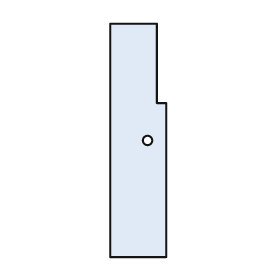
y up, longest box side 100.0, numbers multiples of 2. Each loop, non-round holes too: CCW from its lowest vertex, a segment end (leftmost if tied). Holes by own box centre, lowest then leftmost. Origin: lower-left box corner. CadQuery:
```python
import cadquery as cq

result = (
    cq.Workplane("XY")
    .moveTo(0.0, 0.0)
    .lineTo(24.0, 0.0)
    .lineTo(24.0, 66.0)
    .lineTo(20.0, 66.0)
    .lineTo(20.0, 100.0)
    .lineTo(0.0, 100.0)
    .close()
    .moveTo(16.0, 50.0)
    .circle(2.0)
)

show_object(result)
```